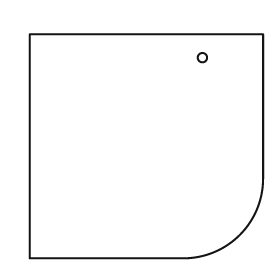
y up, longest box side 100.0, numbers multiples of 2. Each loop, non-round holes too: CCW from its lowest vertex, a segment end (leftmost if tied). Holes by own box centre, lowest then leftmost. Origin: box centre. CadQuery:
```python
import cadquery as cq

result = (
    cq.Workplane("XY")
    .moveTo(-50.0, -48.0)
    .lineTo(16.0, -48.0)
    .threePointArc((40.0, -38.0), (50.0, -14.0))
    .lineTo(50.0, 48.0)
    .lineTo(-50.0, 48.0)
    .close()
    .moveTo(24.0, 38.0)
    .circle(2.0)
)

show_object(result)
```